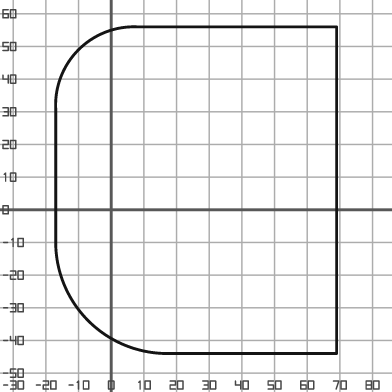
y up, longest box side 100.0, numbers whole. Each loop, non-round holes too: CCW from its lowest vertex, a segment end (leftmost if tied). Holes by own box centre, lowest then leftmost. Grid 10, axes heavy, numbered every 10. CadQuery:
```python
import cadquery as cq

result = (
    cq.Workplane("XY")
    .moveTo(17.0, -44.0)
    .lineTo(69.0, -44.0)
    .lineTo(69.0, 56.0)
    .lineTo(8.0, 56.0)
    .threePointArc((-10.0, 49.0), (-17.0, 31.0))
    .lineTo(-17.0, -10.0)
    .threePointArc((-7.0, -34.0), (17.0, -44.0))
    .close()
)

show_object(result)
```